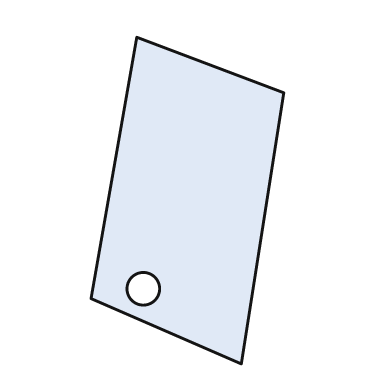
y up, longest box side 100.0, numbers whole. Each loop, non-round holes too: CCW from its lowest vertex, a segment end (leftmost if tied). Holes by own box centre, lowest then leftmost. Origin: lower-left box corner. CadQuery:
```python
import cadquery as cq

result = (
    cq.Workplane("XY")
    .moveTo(46.0, 0.0)
    .lineTo(59.0, 83.0)
    .lineTo(14.0, 100.0)
    .lineTo(0.0, 20.0)
    .close()
    .moveTo(16.0, 23.0)
    .circle(5.0)
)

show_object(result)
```